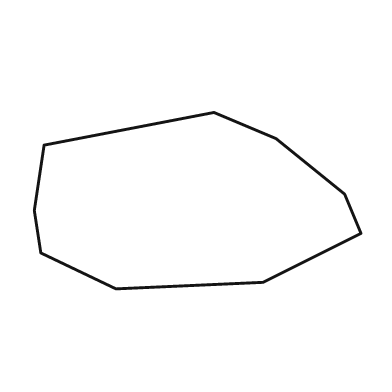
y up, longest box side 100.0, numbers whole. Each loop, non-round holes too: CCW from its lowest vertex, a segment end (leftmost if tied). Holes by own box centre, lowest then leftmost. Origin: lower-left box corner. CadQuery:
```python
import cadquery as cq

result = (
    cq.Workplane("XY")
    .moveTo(25.0, 0.0)
    .lineTo(70.0, 2.0)
    .lineTo(100.0, 17.0)
    .lineTo(95.0, 29.0)
    .lineTo(74.0, 46.0)
    .lineTo(55.0, 54.0)
    .lineTo(3.0, 44.0)
    .lineTo(0.0, 24.0)
    .lineTo(2.0, 11.0)
    .close()
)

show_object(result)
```